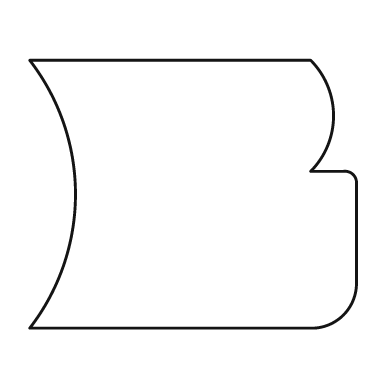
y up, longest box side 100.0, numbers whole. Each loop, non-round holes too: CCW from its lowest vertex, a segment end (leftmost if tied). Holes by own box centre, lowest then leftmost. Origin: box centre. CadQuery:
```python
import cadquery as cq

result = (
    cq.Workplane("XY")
    .moveTo(-50.0, -41.0)
    .lineTo(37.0, -41.0)
    .threePointArc((46.0, -37.0), (50.0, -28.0))
    .lineTo(50.0, 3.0)
    .threePointArc((49.0, 6.0), (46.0, 7.0))
    .lineTo(36.0, 7.0)
    .threePointArc((43.0, 24.0), (36.0, 41.0))
    .lineTo(-50.0, 41.0)
    .threePointArc((-36.0, 0.0), (-50.0, -41.0))
    .close()
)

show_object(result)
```